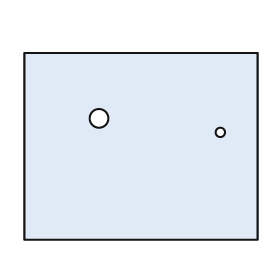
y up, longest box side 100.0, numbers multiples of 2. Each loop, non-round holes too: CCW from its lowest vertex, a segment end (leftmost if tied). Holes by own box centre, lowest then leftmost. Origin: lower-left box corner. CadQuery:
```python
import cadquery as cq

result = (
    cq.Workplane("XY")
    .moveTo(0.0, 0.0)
    .lineTo(100.0, 0.0)
    .lineTo(100.0, 80.0)
    .lineTo(0.0, 80.0)
    .close()
    .moveTo(84.0, 46.0)
    .circle(2.0)
    .moveTo(32.0, 52.0)
    .circle(4.0)
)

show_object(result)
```